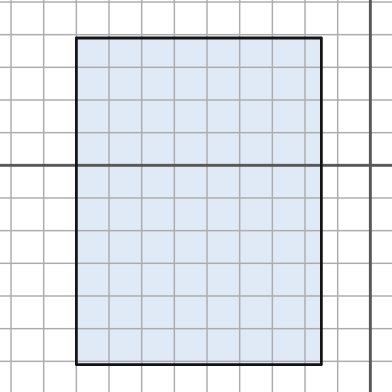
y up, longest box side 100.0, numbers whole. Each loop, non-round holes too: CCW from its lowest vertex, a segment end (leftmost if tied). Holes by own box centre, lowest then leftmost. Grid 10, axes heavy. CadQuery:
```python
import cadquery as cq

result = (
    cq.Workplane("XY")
    .moveTo(-90.0, -61.0)
    .lineTo(-15.0, -61.0)
    .lineTo(-15.0, 39.0)
    .lineTo(-90.0, 39.0)
    .close()
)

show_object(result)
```